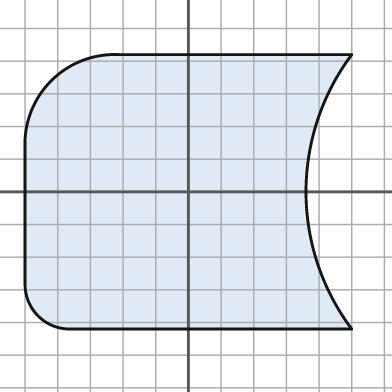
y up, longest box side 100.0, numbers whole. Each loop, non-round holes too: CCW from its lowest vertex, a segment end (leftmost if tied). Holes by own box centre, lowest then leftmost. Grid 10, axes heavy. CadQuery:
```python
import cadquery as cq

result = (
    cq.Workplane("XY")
    .moveTo(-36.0, -42.0)
    .lineTo(50.0, -42.0)
    .threePointArc((36.0, 0.0), (50.0, 42.0))
    .lineTo(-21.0, 42.0)
    .threePointArc((-42.0, 34.0), (-50.0, 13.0))
    .lineTo(-50.0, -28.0)
    .threePointArc((-46.0, -38.0), (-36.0, -42.0))
    .close()
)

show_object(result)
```